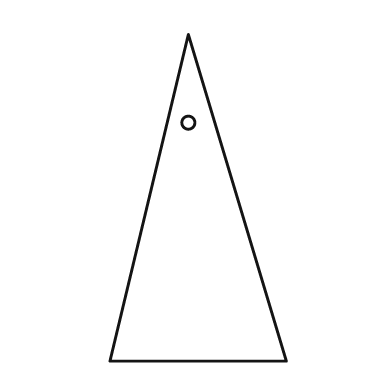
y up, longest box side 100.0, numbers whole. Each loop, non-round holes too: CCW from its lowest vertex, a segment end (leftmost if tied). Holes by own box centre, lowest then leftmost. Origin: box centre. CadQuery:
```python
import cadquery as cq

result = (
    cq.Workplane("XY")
    .moveTo(-27.0, -50.0)
    .lineTo(27.0, -50.0)
    .lineTo(-3.0, 50.0)
    .close()
    .moveTo(-3.0, 23.0)
    .circle(2.0)
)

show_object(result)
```